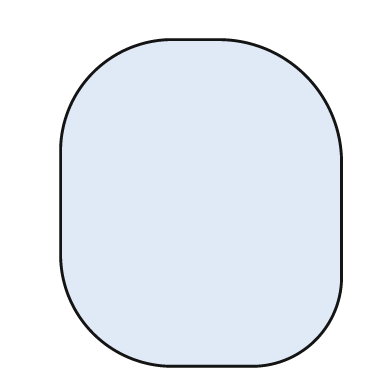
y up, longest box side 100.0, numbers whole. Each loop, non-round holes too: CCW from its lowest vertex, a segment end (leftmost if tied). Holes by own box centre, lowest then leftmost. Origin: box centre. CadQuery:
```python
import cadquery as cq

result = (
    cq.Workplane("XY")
    .moveTo(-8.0, -50.0)
    .lineTo(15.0, -50.0)
    .threePointArc((35.0, -42.0), (43.0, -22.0))
    .lineTo(43.0, 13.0)
    .threePointArc((32.0, 39.0), (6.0, 50.0))
    .lineTo(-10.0, 50.0)
    .threePointArc((-33.0, 40.0), (-43.0, 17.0))
    .lineTo(-43.0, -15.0)
    .threePointArc((-33.0, -40.0), (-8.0, -50.0))
    .close()
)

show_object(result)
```